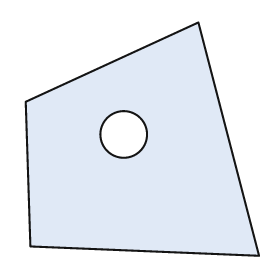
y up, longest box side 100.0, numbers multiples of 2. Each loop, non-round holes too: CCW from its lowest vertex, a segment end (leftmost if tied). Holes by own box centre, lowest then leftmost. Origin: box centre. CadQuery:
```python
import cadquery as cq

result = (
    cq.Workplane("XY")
    .moveTo(50.0, -50.0)
    .lineTo(24.0, 50.0)
    .lineTo(-50.0, 16.0)
    .lineTo(-48.0, -46.0)
    .close()
    .moveTo(-8.0, 2.0)
    .circle(10.0)
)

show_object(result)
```